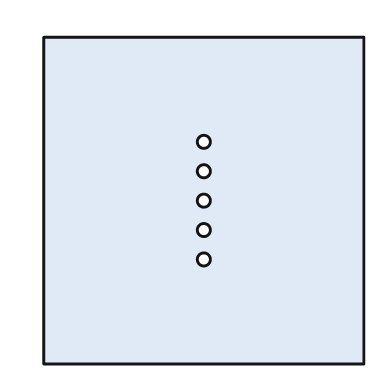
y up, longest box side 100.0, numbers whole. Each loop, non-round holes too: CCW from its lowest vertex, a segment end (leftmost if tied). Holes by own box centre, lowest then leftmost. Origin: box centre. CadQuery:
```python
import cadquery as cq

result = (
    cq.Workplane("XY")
    .moveTo(-49.0, -50.0)
    .lineTo(49.0, -50.0)
    .lineTo(49.0, 50.0)
    .lineTo(-49.0, 50.0)
    .close()
    .moveTo(0.0, -18.0)
    .circle(2.0)
    .moveTo(0.0, -9.0)
    .circle(2.0)
    .moveTo(0.0, 0.0)
    .circle(2.0)
    .moveTo(0.0, 9.0)
    .circle(2.0)
    .moveTo(0.0, 18.0)
    .circle(2.0)
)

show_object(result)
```